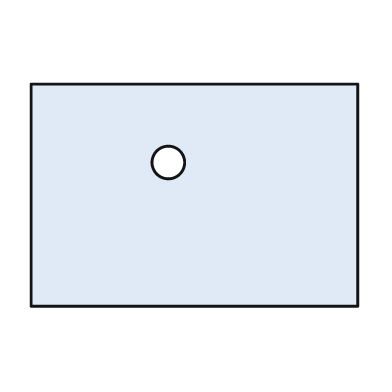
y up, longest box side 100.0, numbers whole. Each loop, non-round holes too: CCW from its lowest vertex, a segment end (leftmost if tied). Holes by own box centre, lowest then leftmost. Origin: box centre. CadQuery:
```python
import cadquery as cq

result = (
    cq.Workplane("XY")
    .moveTo(-50.0, -34.0)
    .lineTo(50.0, -34.0)
    .lineTo(50.0, 34.0)
    .lineTo(-50.0, 34.0)
    .close()
    .moveTo(-8.0, 10.0)
    .circle(5.0)
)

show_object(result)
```